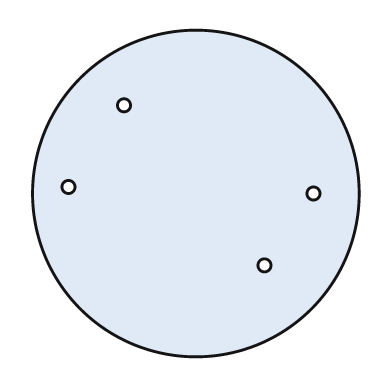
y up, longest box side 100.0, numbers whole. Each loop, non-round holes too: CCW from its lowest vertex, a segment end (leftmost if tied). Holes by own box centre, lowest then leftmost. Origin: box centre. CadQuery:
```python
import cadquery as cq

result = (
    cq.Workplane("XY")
    .moveTo(0.0, 0.0)
    .circle(50.0)
    .moveTo(21.0, -22.0)
    .circle(2.0)
    .moveTo(36.0, 0.0)
    .circle(2.0)
    .moveTo(-39.0, 2.0)
    .circle(2.0)
    .moveTo(-22.0, 27.0)
    .circle(2.0)
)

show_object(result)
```